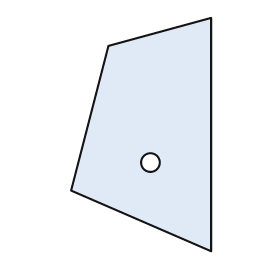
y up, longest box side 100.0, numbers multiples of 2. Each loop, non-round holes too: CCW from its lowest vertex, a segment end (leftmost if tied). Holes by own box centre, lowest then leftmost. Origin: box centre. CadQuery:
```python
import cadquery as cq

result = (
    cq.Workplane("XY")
    .moveTo(30.0, -50.0)
    .lineTo(30.0, 50.0)
    .lineTo(-14.0, 38.0)
    .lineTo(-30.0, -24.0)
    .close()
    .moveTo(4.0, -12.0)
    .circle(4.0)
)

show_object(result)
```